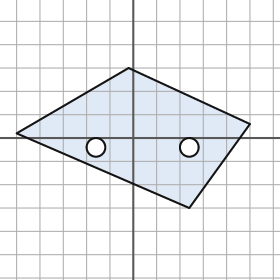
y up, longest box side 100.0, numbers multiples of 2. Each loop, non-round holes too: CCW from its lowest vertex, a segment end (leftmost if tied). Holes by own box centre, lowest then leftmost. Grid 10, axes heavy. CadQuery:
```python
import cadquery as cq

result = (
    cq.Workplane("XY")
    .moveTo(24.0, -30.0)
    .lineTo(50.0, 6.0)
    .lineTo(-2.0, 30.0)
    .lineTo(-50.0, 2.0)
    .close()
    .moveTo(-16.0, -4.0)
    .circle(4.0)
    .moveTo(24.0, -4.0)
    .circle(4.0)
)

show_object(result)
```